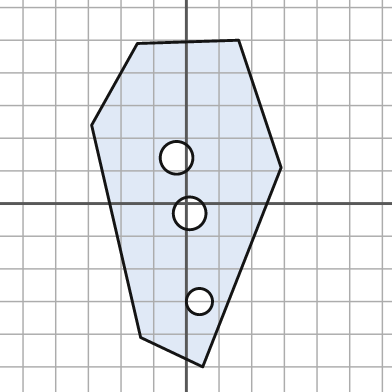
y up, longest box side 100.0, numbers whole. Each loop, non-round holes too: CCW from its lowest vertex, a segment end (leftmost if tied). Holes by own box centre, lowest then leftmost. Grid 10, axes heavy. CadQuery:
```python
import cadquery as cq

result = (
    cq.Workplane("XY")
    .moveTo(5.0, -50.0)
    .lineTo(29.0, 11.0)
    .lineTo(16.0, 50.0)
    .lineTo(-15.0, 49.0)
    .lineTo(-29.0, 24.0)
    .lineTo(-14.0, -41.0)
    .close()
    .moveTo(4.0, -30.0)
    .circle(4.0)
    .moveTo(1.0, -3.0)
    .circle(5.0)
    .moveTo(-3.0, 14.0)
    .circle(5.0)
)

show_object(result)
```